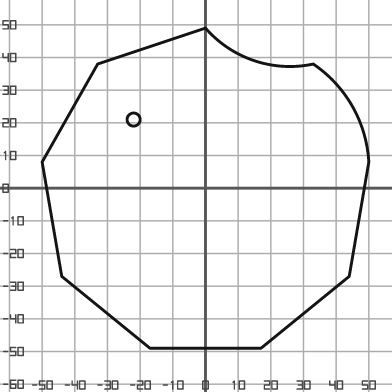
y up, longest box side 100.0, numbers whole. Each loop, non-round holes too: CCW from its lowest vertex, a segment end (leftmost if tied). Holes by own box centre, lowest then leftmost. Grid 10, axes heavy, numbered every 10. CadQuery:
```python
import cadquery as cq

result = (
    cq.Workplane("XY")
    .moveTo(-17.0, -49.0)
    .lineTo(17.0, -49.0)
    .lineTo(44.0, -27.0)
    .lineTo(50.0, 8.0)
    .threePointArc((45.0, 25.0), (33.0, 38.0))
    .threePointArc((15.0, 39.0), (0.0, 49.0))
    .lineTo(-33.0, 38.0)
    .lineTo(-50.0, 8.0)
    .lineTo(-44.0, -27.0)
    .close()
    .moveTo(-22.0, 21.0)
    .circle(2.0)
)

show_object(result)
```